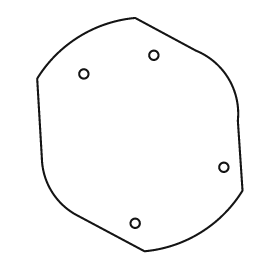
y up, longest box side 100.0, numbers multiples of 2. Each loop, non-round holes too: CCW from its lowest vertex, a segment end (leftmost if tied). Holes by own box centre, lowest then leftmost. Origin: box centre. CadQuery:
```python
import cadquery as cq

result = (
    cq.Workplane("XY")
    .moveTo(2.0, -50.0)
    .threePointArc((26.0, -42.0), (44.0, -24.0))
    .lineTo(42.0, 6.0)
    .threePointArc((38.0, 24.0), (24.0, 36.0))
    .lineTo(-2.0, 50.0)
    .threePointArc((-26.0, 42.0), (-44.0, 24.0))
    .lineTo(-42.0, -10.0)
    .threePointArc((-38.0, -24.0), (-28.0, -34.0))
    .close()
    .moveTo(-2.0, -38.0)
    .circle(2.0)
    .moveTo(36.0, -14.0)
    .circle(2.0)
    .moveTo(-24.0, 26.0)
    .circle(2.0)
    .moveTo(6.0, 34.0)
    .circle(2.0)
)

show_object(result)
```